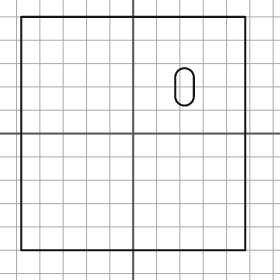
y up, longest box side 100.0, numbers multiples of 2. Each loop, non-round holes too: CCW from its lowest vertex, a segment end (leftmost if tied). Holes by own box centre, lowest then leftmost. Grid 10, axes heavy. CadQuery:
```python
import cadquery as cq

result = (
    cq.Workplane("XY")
    .moveTo(-48.0, -50.0)
    .lineTo(48.0, -50.0)
    .lineTo(48.0, 50.0)
    .lineTo(-48.0, 50.0)
    .close()
    .moveTo(18.0, 16.0)
    .threePointArc((22.0, 12.0), (26.0, 16.0))
    .lineTo(26.0, 24.0)
    .threePointArc((22.0, 28.0), (18.0, 24.0))
    .close()
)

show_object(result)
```